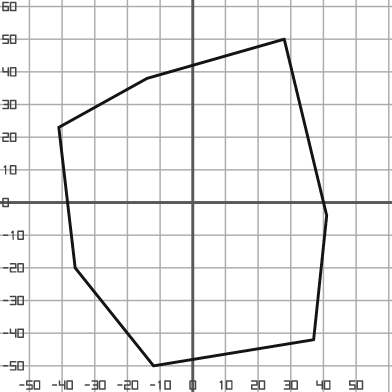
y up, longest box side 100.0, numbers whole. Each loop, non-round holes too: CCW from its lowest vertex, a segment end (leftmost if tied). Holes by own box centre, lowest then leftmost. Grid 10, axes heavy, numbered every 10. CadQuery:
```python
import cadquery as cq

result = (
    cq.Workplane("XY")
    .moveTo(-12.0, -50.0)
    .lineTo(37.0, -42.0)
    .lineTo(41.0, -4.0)
    .lineTo(28.0, 50.0)
    .lineTo(-14.0, 38.0)
    .lineTo(-41.0, 23.0)
    .lineTo(-36.0, -20.0)
    .close()
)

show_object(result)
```